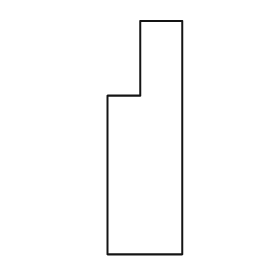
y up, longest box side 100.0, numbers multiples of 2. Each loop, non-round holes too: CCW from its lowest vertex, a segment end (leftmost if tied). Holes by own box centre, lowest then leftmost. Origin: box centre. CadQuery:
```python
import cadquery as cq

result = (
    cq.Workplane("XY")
    .moveTo(-16.0, -50.0)
    .lineTo(16.0, -50.0)
    .lineTo(16.0, 50.0)
    .lineTo(-2.0, 50.0)
    .lineTo(-2.0, 18.0)
    .lineTo(-16.0, 18.0)
    .close()
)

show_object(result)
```